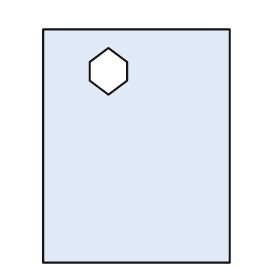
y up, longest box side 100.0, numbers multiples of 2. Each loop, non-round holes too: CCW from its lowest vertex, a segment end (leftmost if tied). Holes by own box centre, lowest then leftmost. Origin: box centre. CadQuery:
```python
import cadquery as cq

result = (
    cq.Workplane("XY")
    .moveTo(-40.0, -50.0)
    .lineTo(40.0, -50.0)
    .lineTo(40.0, 50.0)
    .lineTo(-40.0, 50.0)
    .close()
    .moveTo(-12.0, 22.0)
    .lineTo(-4.0, 28.0)
    .lineTo(-4.0, 36.0)
    .lineTo(-12.0, 42.0)
    .lineTo(-20.0, 36.0)
    .lineTo(-20.0, 28.0)
    .close()
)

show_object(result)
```